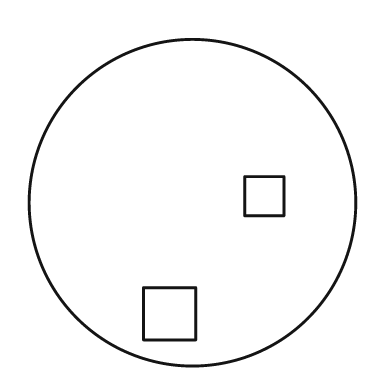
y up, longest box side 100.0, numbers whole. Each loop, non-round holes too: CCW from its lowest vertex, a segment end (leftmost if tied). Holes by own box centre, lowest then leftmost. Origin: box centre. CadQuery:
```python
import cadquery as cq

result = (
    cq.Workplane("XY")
    .moveTo(0.0, 0.0)
    .circle(50.0)
    .moveTo(-15.0, -42.0)
    .lineTo(1.0, -42.0)
    .lineTo(1.0, -26.0)
    .lineTo(-15.0, -26.0)
    .close()
    .moveTo(16.0, -4.0)
    .lineTo(28.0, -4.0)
    .lineTo(28.0, 8.0)
    .lineTo(16.0, 8.0)
    .close()
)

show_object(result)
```